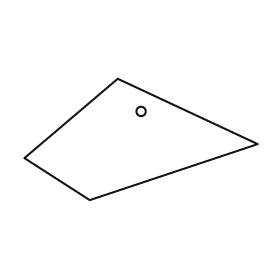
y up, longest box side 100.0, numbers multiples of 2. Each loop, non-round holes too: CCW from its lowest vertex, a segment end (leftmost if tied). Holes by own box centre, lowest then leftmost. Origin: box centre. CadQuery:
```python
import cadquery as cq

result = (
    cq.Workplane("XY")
    .moveTo(-22.0, -26.0)
    .lineTo(50.0, -2.0)
    .lineTo(-10.0, 26.0)
    .lineTo(-50.0, -8.0)
    .close()
    .moveTo(0.0, 12.0)
    .circle(2.0)
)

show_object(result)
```